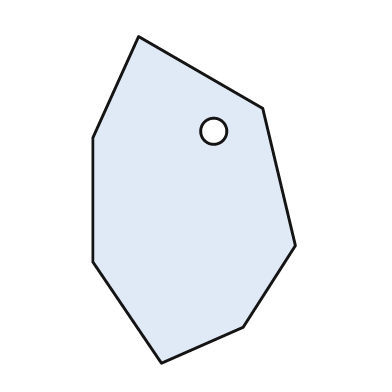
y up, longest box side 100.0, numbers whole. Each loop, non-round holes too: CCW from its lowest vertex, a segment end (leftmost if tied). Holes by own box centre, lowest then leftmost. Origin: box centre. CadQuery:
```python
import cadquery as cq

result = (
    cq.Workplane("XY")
    .moveTo(-10.0, -50.0)
    .lineTo(15.0, -39.0)
    .lineTo(31.0, -14.0)
    .lineTo(21.0, 28.0)
    .lineTo(-17.0, 50.0)
    .lineTo(-31.0, 19.0)
    .lineTo(-31.0, -19.0)
    .close()
    .moveTo(6.0, 21.0)
    .circle(4.0)
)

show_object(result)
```